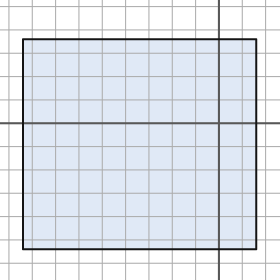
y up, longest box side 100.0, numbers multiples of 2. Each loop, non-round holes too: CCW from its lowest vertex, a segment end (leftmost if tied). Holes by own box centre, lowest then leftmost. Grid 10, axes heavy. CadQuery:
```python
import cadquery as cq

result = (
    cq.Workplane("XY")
    .moveTo(-84.0, -54.0)
    .lineTo(16.0, -54.0)
    .lineTo(16.0, 36.0)
    .lineTo(-84.0, 36.0)
    .close()
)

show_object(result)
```